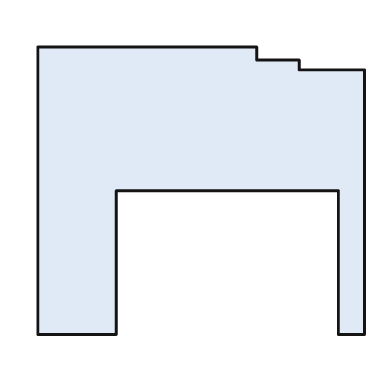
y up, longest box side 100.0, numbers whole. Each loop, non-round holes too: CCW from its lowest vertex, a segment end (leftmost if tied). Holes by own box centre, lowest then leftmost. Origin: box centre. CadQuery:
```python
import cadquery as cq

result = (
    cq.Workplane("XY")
    .moveTo(-50.0, -44.0)
    .lineTo(-26.0, -44.0)
    .lineTo(-26.0, 0.0)
    .lineTo(42.0, 0.0)
    .lineTo(42.0, -44.0)
    .lineTo(50.0, -44.0)
    .lineTo(50.0, 37.0)
    .lineTo(30.0, 37.0)
    .lineTo(30.0, 40.0)
    .lineTo(17.0, 40.0)
    .lineTo(17.0, 44.0)
    .lineTo(-50.0, 44.0)
    .close()
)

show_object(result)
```